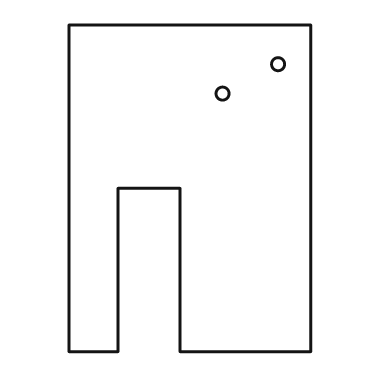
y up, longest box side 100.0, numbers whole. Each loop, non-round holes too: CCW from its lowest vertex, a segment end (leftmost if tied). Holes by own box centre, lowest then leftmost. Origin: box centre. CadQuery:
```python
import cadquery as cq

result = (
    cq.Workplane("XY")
    .moveTo(-37.0, -50.0)
    .lineTo(-22.0, -50.0)
    .lineTo(-22.0, 0.0)
    .lineTo(-3.0, 0.0)
    .lineTo(-3.0, -50.0)
    .lineTo(37.0, -50.0)
    .lineTo(37.0, 50.0)
    .lineTo(-37.0, 50.0)
    .close()
    .moveTo(10.0, 29.0)
    .circle(2.0)
    .moveTo(27.0, 38.0)
    .circle(2.0)
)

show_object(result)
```